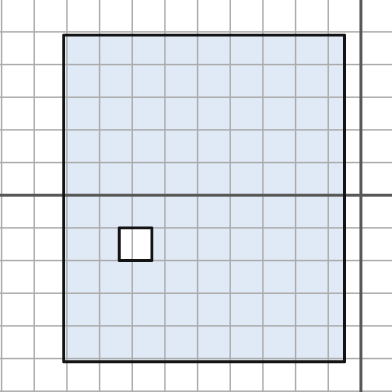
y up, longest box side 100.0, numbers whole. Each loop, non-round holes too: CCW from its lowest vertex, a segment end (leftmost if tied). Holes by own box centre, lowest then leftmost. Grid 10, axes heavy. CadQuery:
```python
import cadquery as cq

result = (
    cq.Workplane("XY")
    .moveTo(-91.0, -51.0)
    .lineTo(-5.0, -51.0)
    .lineTo(-5.0, 49.0)
    .lineTo(-91.0, 49.0)
    .close()
    .moveTo(-74.0, -20.0)
    .lineTo(-64.0, -20.0)
    .lineTo(-64.0, -10.0)
    .lineTo(-74.0, -10.0)
    .close()
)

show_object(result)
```